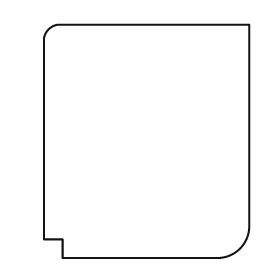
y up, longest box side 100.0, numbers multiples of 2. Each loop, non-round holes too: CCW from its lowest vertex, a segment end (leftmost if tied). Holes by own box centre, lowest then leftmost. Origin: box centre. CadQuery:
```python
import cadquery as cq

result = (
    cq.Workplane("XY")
    .moveTo(-36.0, -50.0)
    .lineTo(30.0, -50.0)
    .threePointArc((40.0, -46.0), (44.0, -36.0))
    .lineTo(44.0, 50.0)
    .lineTo(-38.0, 50.0)
    .threePointArc((-42.0, 48.0), (-44.0, 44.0))
    .lineTo(-44.0, -42.0)
    .lineTo(-36.0, -42.0)
    .close()
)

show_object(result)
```